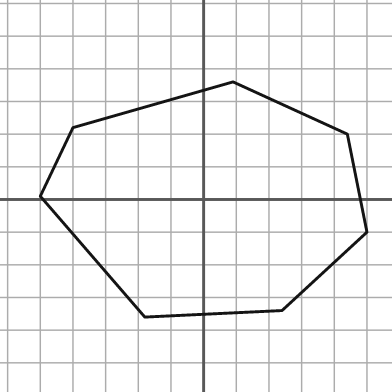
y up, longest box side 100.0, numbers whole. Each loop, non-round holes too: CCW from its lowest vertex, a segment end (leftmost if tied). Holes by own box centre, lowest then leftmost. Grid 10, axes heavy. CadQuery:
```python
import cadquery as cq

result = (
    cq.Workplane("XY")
    .moveTo(-18.0, -36.0)
    .lineTo(24.0, -34.0)
    .lineTo(50.0, -10.0)
    .lineTo(44.0, 20.0)
    .lineTo(9.0, 36.0)
    .lineTo(-40.0, 22.0)
    .lineTo(-50.0, 1.0)
    .close()
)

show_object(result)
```